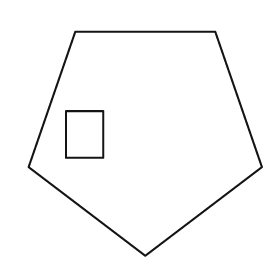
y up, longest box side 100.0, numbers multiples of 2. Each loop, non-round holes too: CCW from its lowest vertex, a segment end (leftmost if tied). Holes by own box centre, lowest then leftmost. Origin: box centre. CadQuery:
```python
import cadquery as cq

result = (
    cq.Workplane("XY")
    .moveTo(0.0, -48.0)
    .lineTo(50.0, -10.0)
    .lineTo(30.0, 48.0)
    .lineTo(-30.0, 48.0)
    .lineTo(-50.0, -10.0)
    .close()
    .moveTo(-34.0, -6.0)
    .lineTo(-18.0, -6.0)
    .lineTo(-18.0, 14.0)
    .lineTo(-34.0, 14.0)
    .close()
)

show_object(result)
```